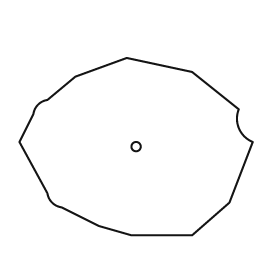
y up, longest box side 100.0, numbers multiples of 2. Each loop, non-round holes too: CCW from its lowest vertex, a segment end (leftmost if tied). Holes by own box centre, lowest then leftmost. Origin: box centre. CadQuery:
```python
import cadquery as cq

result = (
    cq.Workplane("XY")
    .moveTo(-2.0, -38.0)
    .lineTo(24.0, -38.0)
    .lineTo(40.0, -24.0)
    .lineTo(50.0, 2.0)
    .threePointArc((44.0, 8.0), (44.0, 16.0))
    .lineTo(24.0, 32.0)
    .lineTo(-4.0, 38.0)
    .lineTo(-26.0, 30.0)
    .lineTo(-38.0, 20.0)
    .threePointArc((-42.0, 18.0), (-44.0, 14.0))
    .lineTo(-50.0, 2.0)
    .lineTo(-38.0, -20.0)
    .threePointArc((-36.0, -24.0), (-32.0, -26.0))
    .lineTo(-16.0, -34.0)
    .close()
    .moveTo(0.0, 0.0)
    .circle(2.0)
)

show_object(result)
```